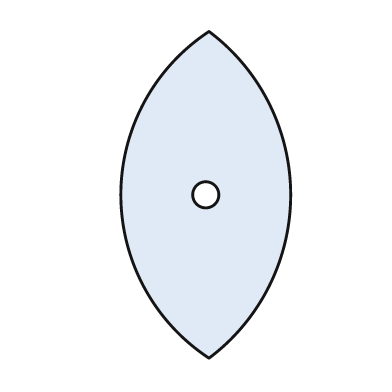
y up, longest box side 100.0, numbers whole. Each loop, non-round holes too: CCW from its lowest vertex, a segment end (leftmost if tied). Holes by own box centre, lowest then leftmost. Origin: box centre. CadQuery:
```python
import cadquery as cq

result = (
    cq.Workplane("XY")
    .moveTo(1.0, -50.0)
    .threePointArc((26.0, 0.0), (1.0, 50.0))
    .threePointArc((-26.0, 0.0), (1.0, -50.0))
    .close()
    .moveTo(0.0, 0.0)
    .circle(4.0)
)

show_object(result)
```